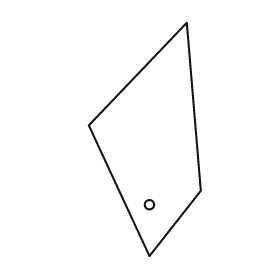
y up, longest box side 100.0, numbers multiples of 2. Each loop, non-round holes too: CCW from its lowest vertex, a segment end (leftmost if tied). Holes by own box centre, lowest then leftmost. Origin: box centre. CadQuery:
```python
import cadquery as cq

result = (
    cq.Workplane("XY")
    .moveTo(2.0, -50.0)
    .lineTo(24.0, -22.0)
    .lineTo(18.0, 50.0)
    .lineTo(-24.0, 6.0)
    .close()
    .moveTo(2.0, -28.0)
    .circle(2.0)
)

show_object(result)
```